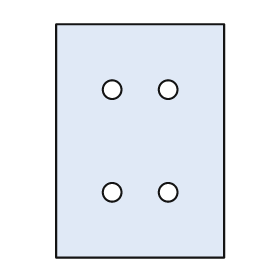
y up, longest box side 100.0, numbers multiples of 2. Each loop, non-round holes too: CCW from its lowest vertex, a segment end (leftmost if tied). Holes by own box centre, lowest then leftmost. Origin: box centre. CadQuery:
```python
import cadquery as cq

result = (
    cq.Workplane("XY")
    .moveTo(-36.0, -50.0)
    .lineTo(36.0, -50.0)
    .lineTo(36.0, 50.0)
    .lineTo(-36.0, 50.0)
    .close()
    .moveTo(-12.0, -22.0)
    .circle(4.0)
    .moveTo(12.0, -22.0)
    .circle(4.0)
    .moveTo(-12.0, 22.0)
    .circle(4.0)
    .moveTo(12.0, 22.0)
    .circle(4.0)
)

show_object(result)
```